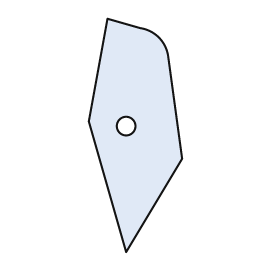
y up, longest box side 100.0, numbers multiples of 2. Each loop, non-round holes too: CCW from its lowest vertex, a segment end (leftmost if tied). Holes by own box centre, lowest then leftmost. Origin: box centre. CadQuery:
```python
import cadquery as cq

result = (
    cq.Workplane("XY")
    .moveTo(-4.0, -50.0)
    .lineTo(20.0, -10.0)
    .lineTo(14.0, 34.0)
    .threePointArc((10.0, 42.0), (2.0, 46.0))
    .lineTo(-12.0, 50.0)
    .lineTo(-20.0, 6.0)
    .close()
    .moveTo(-4.0, 4.0)
    .circle(4.0)
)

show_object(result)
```